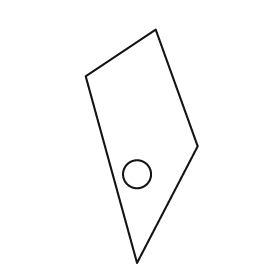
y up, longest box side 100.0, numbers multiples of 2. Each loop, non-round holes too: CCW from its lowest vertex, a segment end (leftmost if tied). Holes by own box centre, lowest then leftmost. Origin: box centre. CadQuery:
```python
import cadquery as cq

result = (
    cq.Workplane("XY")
    .moveTo(-2.0, -50.0)
    .lineTo(24.0, 0.0)
    .lineTo(6.0, 50.0)
    .lineTo(-24.0, 30.0)
    .close()
    .moveTo(-2.0, -12.0)
    .circle(6.0)
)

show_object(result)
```